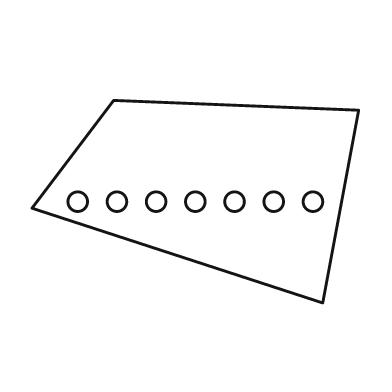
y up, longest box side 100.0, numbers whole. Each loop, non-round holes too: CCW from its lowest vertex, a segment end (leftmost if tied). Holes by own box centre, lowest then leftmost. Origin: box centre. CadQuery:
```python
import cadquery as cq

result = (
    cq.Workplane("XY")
    .moveTo(39.0, -31.0)
    .lineTo(50.0, 28.0)
    .lineTo(-25.0, 31.0)
    .lineTo(-50.0, -2.0)
    .close()
    .moveTo(-36.0, 0.0)
    .circle(3.0)
    .moveTo(-24.0, 0.0)
    .circle(3.0)
    .moveTo(-12.0, 0.0)
    .circle(3.0)
    .moveTo(0.0, 0.0)
    .circle(3.0)
    .moveTo(12.0, 0.0)
    .circle(3.0)
    .moveTo(24.0, 0.0)
    .circle(3.0)
    .moveTo(36.0, 0.0)
    .circle(3.0)
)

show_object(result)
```